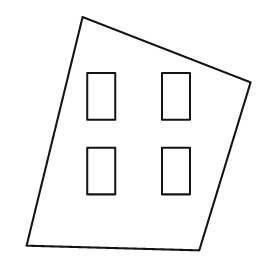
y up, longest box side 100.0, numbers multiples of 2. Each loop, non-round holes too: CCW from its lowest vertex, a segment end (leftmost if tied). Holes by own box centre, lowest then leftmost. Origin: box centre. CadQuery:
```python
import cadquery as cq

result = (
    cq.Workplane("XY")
    .moveTo(26.0, -50.0)
    .lineTo(48.0, 22.0)
    .lineTo(-24.0, 50.0)
    .lineTo(-48.0, -48.0)
    .close()
    .moveTo(-22.0, -26.0)
    .lineTo(-10.0, -26.0)
    .lineTo(-10.0, -6.0)
    .lineTo(-22.0, -6.0)
    .close()
    .moveTo(10.0, -26.0)
    .lineTo(22.0, -26.0)
    .lineTo(22.0, -6.0)
    .lineTo(10.0, -6.0)
    .close()
    .moveTo(-22.0, 6.0)
    .lineTo(-10.0, 6.0)
    .lineTo(-10.0, 26.0)
    .lineTo(-22.0, 26.0)
    .close()
    .moveTo(10.0, 6.0)
    .lineTo(22.0, 6.0)
    .lineTo(22.0, 26.0)
    .lineTo(10.0, 26.0)
    .close()
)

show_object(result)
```